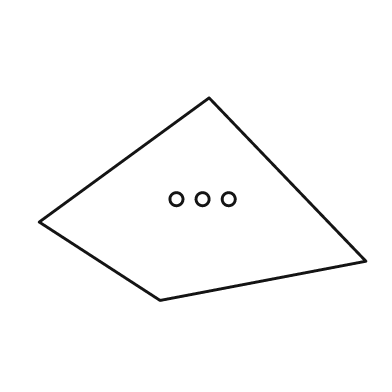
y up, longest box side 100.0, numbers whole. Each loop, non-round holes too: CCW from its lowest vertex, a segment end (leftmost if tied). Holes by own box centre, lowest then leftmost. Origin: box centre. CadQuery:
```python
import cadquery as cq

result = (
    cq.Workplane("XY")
    .moveTo(-13.0, -31.0)
    .lineTo(50.0, -19.0)
    .lineTo(2.0, 31.0)
    .lineTo(-50.0, -7.0)
    .close()
    .moveTo(-8.0, 0.0)
    .circle(2.0)
    .moveTo(0.0, 0.0)
    .circle(2.0)
    .moveTo(8.0, 0.0)
    .circle(2.0)
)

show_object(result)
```